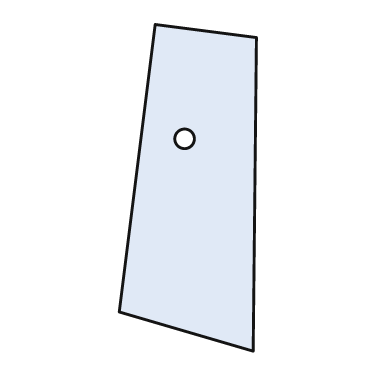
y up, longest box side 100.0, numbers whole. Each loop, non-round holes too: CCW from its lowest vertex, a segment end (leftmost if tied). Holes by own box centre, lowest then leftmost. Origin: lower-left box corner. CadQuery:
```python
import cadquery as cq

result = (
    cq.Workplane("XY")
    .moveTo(41.0, 0.0)
    .lineTo(42.0, 96.0)
    .lineTo(11.0, 100.0)
    .lineTo(0.0, 12.0)
    .close()
    .moveTo(20.0, 65.0)
    .circle(3.0)
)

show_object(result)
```